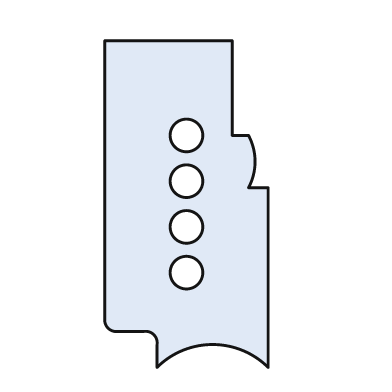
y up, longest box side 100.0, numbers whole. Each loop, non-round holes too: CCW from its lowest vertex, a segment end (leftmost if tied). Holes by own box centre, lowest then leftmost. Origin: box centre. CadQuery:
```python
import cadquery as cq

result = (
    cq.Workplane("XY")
    .moveTo(-9.0, -50.0)
    .threePointArc((8.0, -43.0), (25.0, -50.0))
    .lineTo(25.0, 5.0)
    .lineTo(19.0, 5.0)
    .threePointArc((21.0, 13.0), (19.0, 21.0))
    .lineTo(14.0, 21.0)
    .lineTo(14.0, 50.0)
    .lineTo(-25.0, 50.0)
    .lineTo(-25.0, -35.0)
    .threePointArc((-24.0, -38.0), (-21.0, -39.0))
    .lineTo(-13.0, -39.0)
    .threePointArc((-10.0, -40.0), (-9.0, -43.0))
    .close()
    .moveTo(0.0, -21.0)
    .circle(5.0)
    .moveTo(0.0, -7.0)
    .circle(5.0)
    .moveTo(0.0, 7.0)
    .circle(5.0)
    .moveTo(0.0, 21.0)
    .circle(5.0)
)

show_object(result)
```